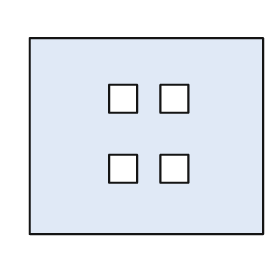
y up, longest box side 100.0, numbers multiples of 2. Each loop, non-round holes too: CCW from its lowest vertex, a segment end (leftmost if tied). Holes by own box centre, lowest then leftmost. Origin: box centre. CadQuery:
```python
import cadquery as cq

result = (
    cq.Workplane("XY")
    .moveTo(-50.0, -42.0)
    .lineTo(50.0, -42.0)
    .lineTo(50.0, 42.0)
    .lineTo(-50.0, 42.0)
    .close()
    .moveTo(-16.0, -20.0)
    .lineTo(-4.0, -20.0)
    .lineTo(-4.0, -8.0)
    .lineTo(-16.0, -8.0)
    .close()
    .moveTo(6.0, -20.0)
    .lineTo(18.0, -20.0)
    .lineTo(18.0, -8.0)
    .lineTo(6.0, -8.0)
    .close()
    .moveTo(-16.0, 10.0)
    .lineTo(-4.0, 10.0)
    .lineTo(-4.0, 22.0)
    .lineTo(-16.0, 22.0)
    .close()
    .moveTo(6.0, 10.0)
    .lineTo(18.0, 10.0)
    .lineTo(18.0, 22.0)
    .lineTo(6.0, 22.0)
    .close()
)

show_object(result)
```